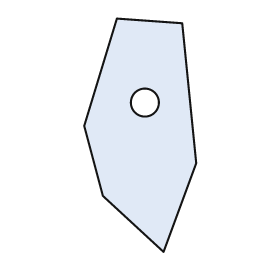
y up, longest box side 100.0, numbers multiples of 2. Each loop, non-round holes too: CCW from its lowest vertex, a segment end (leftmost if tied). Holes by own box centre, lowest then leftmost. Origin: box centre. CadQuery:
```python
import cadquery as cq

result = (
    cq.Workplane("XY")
    .moveTo(10.0, -50.0)
    .lineTo(24.0, -12.0)
    .lineTo(18.0, 48.0)
    .lineTo(-10.0, 50.0)
    .lineTo(-24.0, 4.0)
    .lineTo(-16.0, -26.0)
    .close()
    .moveTo(2.0, 14.0)
    .circle(6.0)
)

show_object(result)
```